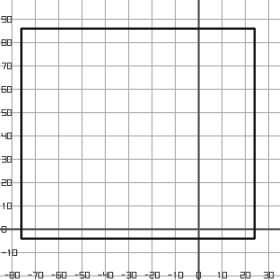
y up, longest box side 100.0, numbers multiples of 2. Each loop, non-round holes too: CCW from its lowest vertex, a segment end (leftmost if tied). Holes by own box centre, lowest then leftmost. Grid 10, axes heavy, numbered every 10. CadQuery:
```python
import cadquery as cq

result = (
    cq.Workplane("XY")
    .moveTo(-76.0, -4.0)
    .lineTo(24.0, -4.0)
    .lineTo(24.0, 86.0)
    .lineTo(-76.0, 86.0)
    .close()
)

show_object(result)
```